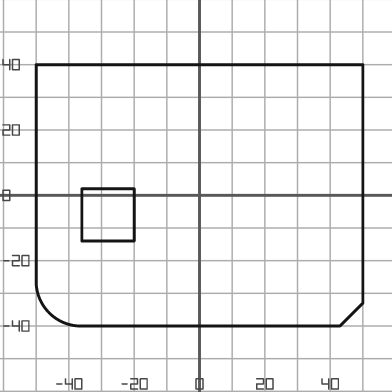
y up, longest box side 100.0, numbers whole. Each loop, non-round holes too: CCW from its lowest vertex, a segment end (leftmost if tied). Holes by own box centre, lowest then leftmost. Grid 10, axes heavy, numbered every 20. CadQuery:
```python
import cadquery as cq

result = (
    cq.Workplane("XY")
    .moveTo(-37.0, -40.0)
    .lineTo(43.0, -40.0)
    .lineTo(50.0, -33.0)
    .lineTo(50.0, 40.0)
    .lineTo(-50.0, 40.0)
    .lineTo(-50.0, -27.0)
    .threePointArc((-46.0, -36.0), (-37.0, -40.0))
    .close()
    .moveTo(-36.0, -14.0)
    .lineTo(-20.0, -14.0)
    .lineTo(-20.0, 2.0)
    .lineTo(-36.0, 2.0)
    .close()
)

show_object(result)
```